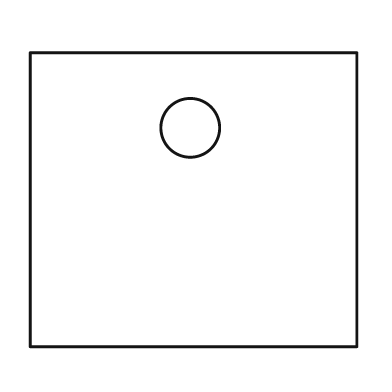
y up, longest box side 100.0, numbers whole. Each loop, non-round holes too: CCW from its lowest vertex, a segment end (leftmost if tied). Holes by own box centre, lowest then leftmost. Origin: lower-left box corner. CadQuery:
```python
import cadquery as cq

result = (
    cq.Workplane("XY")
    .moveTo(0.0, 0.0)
    .lineTo(100.0, 0.0)
    .lineTo(100.0, 90.0)
    .lineTo(0.0, 90.0)
    .close()
    .moveTo(49.0, 67.0)
    .circle(9.0)
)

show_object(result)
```